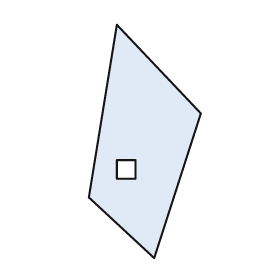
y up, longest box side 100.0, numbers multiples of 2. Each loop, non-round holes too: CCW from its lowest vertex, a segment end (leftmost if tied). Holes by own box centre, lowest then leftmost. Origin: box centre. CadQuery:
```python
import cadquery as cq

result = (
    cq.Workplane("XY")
    .moveTo(4.0, -50.0)
    .lineTo(24.0, 12.0)
    .lineTo(-12.0, 50.0)
    .lineTo(-24.0, -24.0)
    .close()
    .moveTo(-12.0, -16.0)
    .lineTo(-4.0, -16.0)
    .lineTo(-4.0, -8.0)
    .lineTo(-12.0, -8.0)
    .close()
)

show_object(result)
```